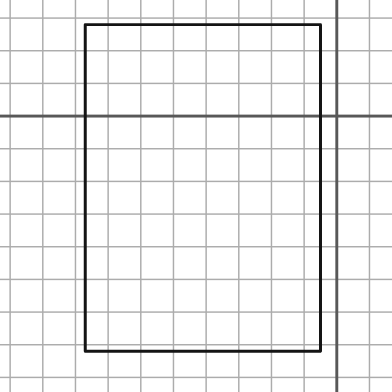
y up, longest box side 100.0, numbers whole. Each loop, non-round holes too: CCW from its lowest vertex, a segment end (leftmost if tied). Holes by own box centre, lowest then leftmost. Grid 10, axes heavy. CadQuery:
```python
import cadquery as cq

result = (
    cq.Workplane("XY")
    .moveTo(-77.0, -72.0)
    .lineTo(-5.0, -72.0)
    .lineTo(-5.0, 28.0)
    .lineTo(-77.0, 28.0)
    .close()
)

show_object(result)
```